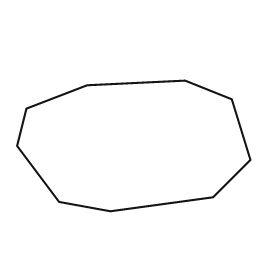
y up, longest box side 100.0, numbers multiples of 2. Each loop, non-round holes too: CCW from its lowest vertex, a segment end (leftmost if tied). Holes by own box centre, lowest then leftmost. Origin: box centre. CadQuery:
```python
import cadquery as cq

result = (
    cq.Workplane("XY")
    .moveTo(-10.0, -28.0)
    .lineTo(34.0, -22.0)
    .lineTo(50.0, -6.0)
    .lineTo(42.0, 20.0)
    .lineTo(22.0, 28.0)
    .lineTo(-20.0, 26.0)
    .lineTo(-46.0, 16.0)
    .lineTo(-50.0, 0.0)
    .lineTo(-32.0, -24.0)
    .close()
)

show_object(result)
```